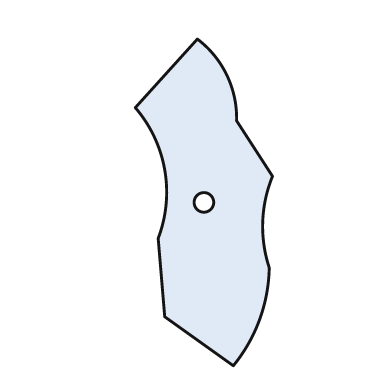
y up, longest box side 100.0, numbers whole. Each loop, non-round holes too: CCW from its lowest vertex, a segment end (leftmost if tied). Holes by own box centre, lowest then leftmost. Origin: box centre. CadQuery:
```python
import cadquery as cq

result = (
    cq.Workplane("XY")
    .moveTo(9.0, -50.0)
    .threePointArc((17.0, -36.0), (20.0, -20.0))
    .threePointArc((18.0, -6.0), (21.0, 8.0))
    .lineTo(10.0, 25.0)
    .threePointArc((7.0, 39.0), (-2.0, 50.0))
    .lineTo(-21.0, 29.0)
    .threePointArc((-12.0, 10.0), (-14.0, -11.0))
    .lineTo(-12.0, -35.0)
    .close()
    .moveTo(0.0, 0.0)
    .circle(3.0)
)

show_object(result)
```